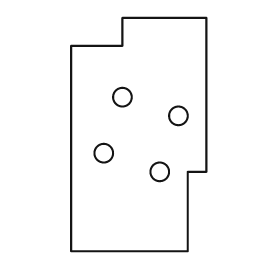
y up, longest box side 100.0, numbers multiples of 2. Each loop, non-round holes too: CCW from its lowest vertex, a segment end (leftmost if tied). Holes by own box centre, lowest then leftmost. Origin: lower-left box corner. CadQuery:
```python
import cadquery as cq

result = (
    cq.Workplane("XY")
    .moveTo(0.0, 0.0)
    .lineTo(50.0, 0.0)
    .lineTo(50.0, 34.0)
    .lineTo(58.0, 34.0)
    .lineTo(58.0, 100.0)
    .lineTo(22.0, 100.0)
    .lineTo(22.0, 88.0)
    .lineTo(0.0, 88.0)
    .close()
    .moveTo(38.0, 34.0)
    .circle(4.0)
    .moveTo(14.0, 42.0)
    .circle(4.0)
    .moveTo(46.0, 58.0)
    .circle(4.0)
    .moveTo(22.0, 66.0)
    .circle(4.0)
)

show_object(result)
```